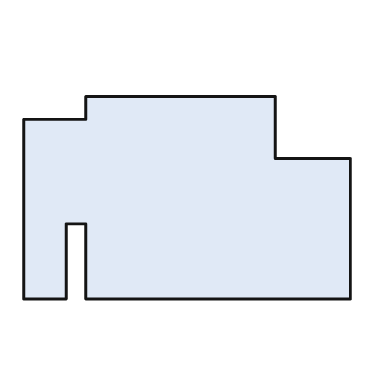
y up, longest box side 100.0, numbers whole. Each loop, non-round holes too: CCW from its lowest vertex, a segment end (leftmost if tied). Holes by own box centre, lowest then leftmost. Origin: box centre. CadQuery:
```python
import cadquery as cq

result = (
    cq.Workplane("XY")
    .moveTo(-50.0, -31.0)
    .lineTo(-37.0, -31.0)
    .lineTo(-37.0, -8.0)
    .lineTo(-31.0, -8.0)
    .lineTo(-31.0, -31.0)
    .lineTo(50.0, -31.0)
    .lineTo(50.0, 12.0)
    .lineTo(27.0, 12.0)
    .lineTo(27.0, 31.0)
    .lineTo(-31.0, 31.0)
    .lineTo(-31.0, 24.0)
    .lineTo(-50.0, 24.0)
    .close()
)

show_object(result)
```